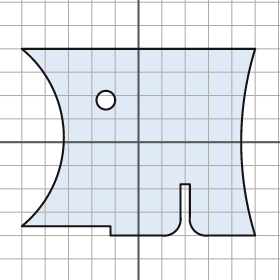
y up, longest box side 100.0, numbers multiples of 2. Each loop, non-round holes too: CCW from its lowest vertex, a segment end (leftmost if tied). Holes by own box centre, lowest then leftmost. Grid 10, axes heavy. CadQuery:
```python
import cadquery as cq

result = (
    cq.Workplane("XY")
    .moveTo(-12.0, -40.0)
    .lineTo(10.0, -40.0)
    .threePointArc((16.0, -38.0), (18.0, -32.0))
    .lineTo(18.0, -18.0)
    .lineTo(22.0, -18.0)
    .lineTo(22.0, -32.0)
    .threePointArc((24.0, -38.0), (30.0, -40.0))
    .lineTo(50.0, -40.0)
    .threePointArc((44.0, 0.0), (50.0, 40.0))
    .lineTo(-50.0, 40.0)
    .threePointArc((-32.0, 2.0), (-50.0, -36.0))
    .lineTo(-12.0, -36.0)
    .close()
    .moveTo(-14.0, 18.0)
    .circle(4.0)
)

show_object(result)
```